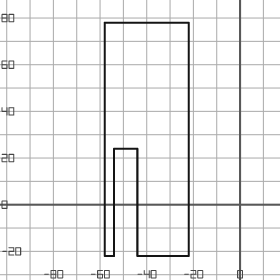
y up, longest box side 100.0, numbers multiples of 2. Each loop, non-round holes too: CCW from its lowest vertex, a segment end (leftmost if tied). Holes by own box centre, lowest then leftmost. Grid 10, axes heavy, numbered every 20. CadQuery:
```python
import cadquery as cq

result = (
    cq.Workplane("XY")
    .moveTo(-58.0, -22.0)
    .lineTo(-54.0, -22.0)
    .lineTo(-54.0, 24.0)
    .lineTo(-44.0, 24.0)
    .lineTo(-44.0, -22.0)
    .lineTo(-22.0, -22.0)
    .lineTo(-22.0, 78.0)
    .lineTo(-58.0, 78.0)
    .close()
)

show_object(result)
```